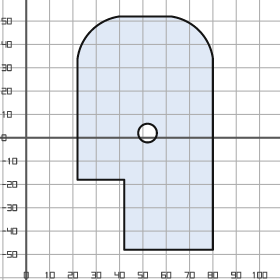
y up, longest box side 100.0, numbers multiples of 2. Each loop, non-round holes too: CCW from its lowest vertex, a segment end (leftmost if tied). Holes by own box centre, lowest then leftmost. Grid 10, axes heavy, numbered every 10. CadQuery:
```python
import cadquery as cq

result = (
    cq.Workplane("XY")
    .moveTo(42.0, -48.0)
    .lineTo(80.0, -48.0)
    .lineTo(80.0, 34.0)
    .threePointArc((74.0, 46.0), (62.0, 52.0))
    .lineTo(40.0, 52.0)
    .threePointArc((28.0, 46.0), (22.0, 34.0))
    .lineTo(22.0, -18.0)
    .lineTo(42.0, -18.0)
    .close()
    .moveTo(52.0, 2.0)
    .circle(4.0)
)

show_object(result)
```